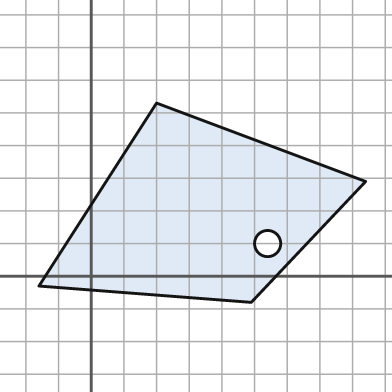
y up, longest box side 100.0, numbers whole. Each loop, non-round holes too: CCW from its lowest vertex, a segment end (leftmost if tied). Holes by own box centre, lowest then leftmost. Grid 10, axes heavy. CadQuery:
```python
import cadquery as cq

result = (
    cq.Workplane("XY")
    .moveTo(49.0, -8.0)
    .lineTo(84.0, 29.0)
    .lineTo(20.0, 53.0)
    .lineTo(-16.0, -3.0)
    .close()
    .moveTo(54.0, 10.0)
    .circle(4.0)
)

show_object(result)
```